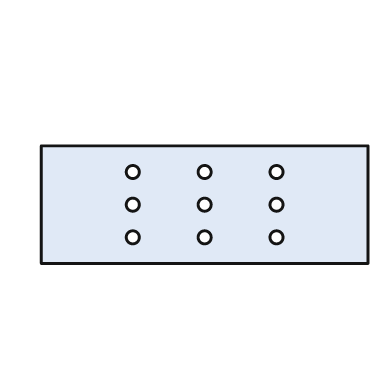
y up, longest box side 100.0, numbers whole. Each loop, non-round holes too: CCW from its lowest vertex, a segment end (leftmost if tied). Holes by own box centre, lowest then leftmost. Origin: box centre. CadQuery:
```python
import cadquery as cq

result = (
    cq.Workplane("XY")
    .moveTo(-50.0, -18.0)
    .lineTo(50.0, -18.0)
    .lineTo(50.0, 18.0)
    .lineTo(-50.0, 18.0)
    .close()
    .moveTo(-22.0, -10.0)
    .circle(2.0)
    .moveTo(0.0, -10.0)
    .circle(2.0)
    .moveTo(22.0, -10.0)
    .circle(2.0)
    .moveTo(-22.0, 0.0)
    .circle(2.0)
    .moveTo(0.0, 0.0)
    .circle(2.0)
    .moveTo(22.0, 0.0)
    .circle(2.0)
    .moveTo(-22.0, 10.0)
    .circle(2.0)
    .moveTo(0.0, 10.0)
    .circle(2.0)
    .moveTo(22.0, 10.0)
    .circle(2.0)
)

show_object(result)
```